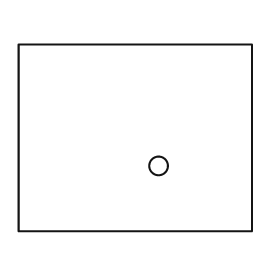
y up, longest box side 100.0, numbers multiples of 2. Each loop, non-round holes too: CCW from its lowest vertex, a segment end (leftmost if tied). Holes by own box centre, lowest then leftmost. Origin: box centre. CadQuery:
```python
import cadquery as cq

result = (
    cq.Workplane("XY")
    .moveTo(-50.0, -40.0)
    .lineTo(50.0, -40.0)
    .lineTo(50.0, 40.0)
    .lineTo(-50.0, 40.0)
    .close()
    .moveTo(10.0, -12.0)
    .circle(4.0)
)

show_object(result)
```